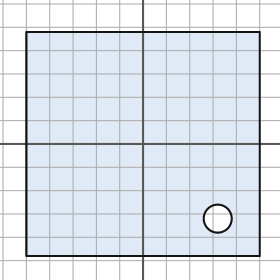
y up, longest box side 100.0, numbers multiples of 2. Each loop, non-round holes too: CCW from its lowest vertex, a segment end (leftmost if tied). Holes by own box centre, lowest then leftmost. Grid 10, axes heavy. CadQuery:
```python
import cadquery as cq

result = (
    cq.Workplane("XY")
    .moveTo(-50.0, -48.0)
    .lineTo(50.0, -48.0)
    .lineTo(50.0, 48.0)
    .lineTo(-50.0, 48.0)
    .close()
    .moveTo(32.0, -32.0)
    .circle(6.0)
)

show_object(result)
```